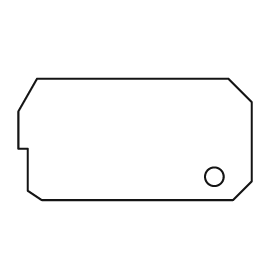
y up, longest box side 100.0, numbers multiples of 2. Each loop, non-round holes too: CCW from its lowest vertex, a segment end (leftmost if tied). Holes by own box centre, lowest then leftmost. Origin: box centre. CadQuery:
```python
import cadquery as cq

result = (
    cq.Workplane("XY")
    .moveTo(-40.0, -26.0)
    .lineTo(42.0, -26.0)
    .lineTo(50.0, -18.0)
    .lineTo(50.0, 16.0)
    .lineTo(40.0, 26.0)
    .lineTo(-42.0, 26.0)
    .lineTo(-50.0, 12.0)
    .lineTo(-50.0, -4.0)
    .lineTo(-46.0, -4.0)
    .lineTo(-46.0, -22.0)
    .close()
    .moveTo(34.0, -16.0)
    .circle(4.0)
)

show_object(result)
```